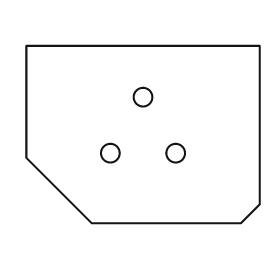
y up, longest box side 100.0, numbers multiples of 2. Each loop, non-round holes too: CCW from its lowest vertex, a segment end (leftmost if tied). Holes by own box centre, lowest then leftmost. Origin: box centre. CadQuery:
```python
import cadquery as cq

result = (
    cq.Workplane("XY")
    .moveTo(-22.0, -38.0)
    .lineTo(42.0, -38.0)
    .lineTo(50.0, -30.0)
    .lineTo(50.0, 38.0)
    .lineTo(-50.0, 38.0)
    .lineTo(-50.0, -10.0)
    .close()
    .moveTo(-14.0, -8.0)
    .circle(4.0)
    .moveTo(14.0, -8.0)
    .circle(4.0)
    .moveTo(0.0, 16.0)
    .circle(4.0)
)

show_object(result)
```